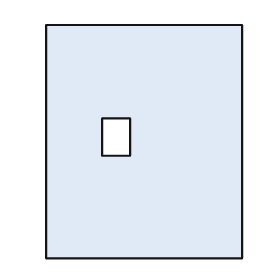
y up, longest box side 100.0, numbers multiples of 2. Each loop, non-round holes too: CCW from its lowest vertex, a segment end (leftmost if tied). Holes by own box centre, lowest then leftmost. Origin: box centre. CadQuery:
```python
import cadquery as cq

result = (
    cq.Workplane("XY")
    .moveTo(-42.0, -50.0)
    .lineTo(42.0, -50.0)
    .lineTo(42.0, 50.0)
    .lineTo(-42.0, 50.0)
    .close()
    .moveTo(-18.0, -6.0)
    .lineTo(-6.0, -6.0)
    .lineTo(-6.0, 10.0)
    .lineTo(-18.0, 10.0)
    .close()
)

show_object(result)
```